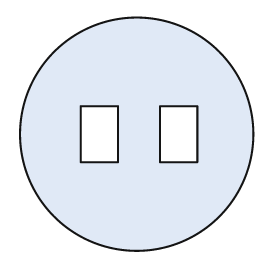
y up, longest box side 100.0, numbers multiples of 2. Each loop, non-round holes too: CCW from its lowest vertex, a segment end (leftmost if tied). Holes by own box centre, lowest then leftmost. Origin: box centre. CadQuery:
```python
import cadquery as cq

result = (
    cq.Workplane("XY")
    .moveTo(0.0, 0.0)
    .circle(50.0)
    .moveTo(-24.0, -12.0)
    .lineTo(-8.0, -12.0)
    .lineTo(-8.0, 12.0)
    .lineTo(-24.0, 12.0)
    .close()
    .moveTo(10.0, -12.0)
    .lineTo(26.0, -12.0)
    .lineTo(26.0, 12.0)
    .lineTo(10.0, 12.0)
    .close()
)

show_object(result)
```